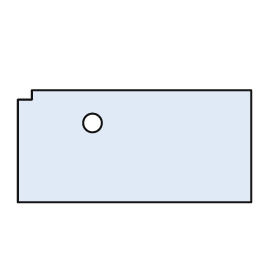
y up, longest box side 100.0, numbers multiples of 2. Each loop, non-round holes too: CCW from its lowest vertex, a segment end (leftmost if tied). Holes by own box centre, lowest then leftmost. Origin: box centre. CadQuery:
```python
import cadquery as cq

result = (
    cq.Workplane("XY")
    .moveTo(-50.0, -24.0)
    .lineTo(50.0, -24.0)
    .lineTo(50.0, 24.0)
    .lineTo(-44.0, 24.0)
    .lineTo(-44.0, 20.0)
    .lineTo(-50.0, 20.0)
    .close()
    .moveTo(-18.0, 10.0)
    .circle(4.0)
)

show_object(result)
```